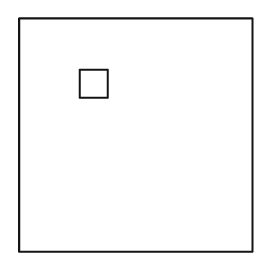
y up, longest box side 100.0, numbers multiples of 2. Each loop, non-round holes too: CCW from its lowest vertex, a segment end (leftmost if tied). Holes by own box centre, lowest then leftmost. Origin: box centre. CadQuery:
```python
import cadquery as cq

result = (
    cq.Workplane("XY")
    .moveTo(-50.0, -50.0)
    .lineTo(50.0, -50.0)
    .lineTo(50.0, 50.0)
    .lineTo(-50.0, 50.0)
    .close()
    .moveTo(-24.0, 16.0)
    .lineTo(-12.0, 16.0)
    .lineTo(-12.0, 28.0)
    .lineTo(-24.0, 28.0)
    .close()
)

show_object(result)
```